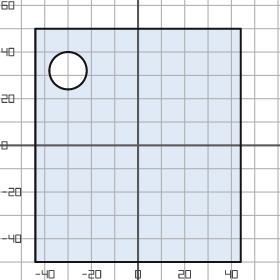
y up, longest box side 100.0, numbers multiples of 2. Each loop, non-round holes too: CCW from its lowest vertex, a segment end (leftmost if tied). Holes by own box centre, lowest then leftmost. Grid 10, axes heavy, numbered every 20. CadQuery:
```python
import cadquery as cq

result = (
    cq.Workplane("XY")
    .moveTo(-44.0, -50.0)
    .lineTo(44.0, -50.0)
    .lineTo(44.0, 50.0)
    .lineTo(-44.0, 50.0)
    .close()
    .moveTo(-30.0, 32.0)
    .circle(8.0)
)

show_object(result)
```